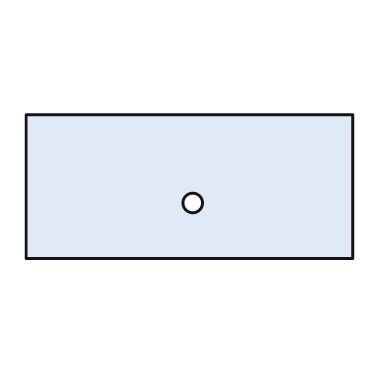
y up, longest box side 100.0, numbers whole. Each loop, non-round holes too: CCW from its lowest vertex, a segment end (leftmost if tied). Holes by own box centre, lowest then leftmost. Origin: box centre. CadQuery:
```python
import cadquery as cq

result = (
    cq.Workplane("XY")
    .moveTo(-50.0, -22.0)
    .lineTo(50.0, -22.0)
    .lineTo(50.0, 22.0)
    .lineTo(-50.0, 22.0)
    .close()
    .moveTo(1.0, -5.0)
    .circle(3.0)
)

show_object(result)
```